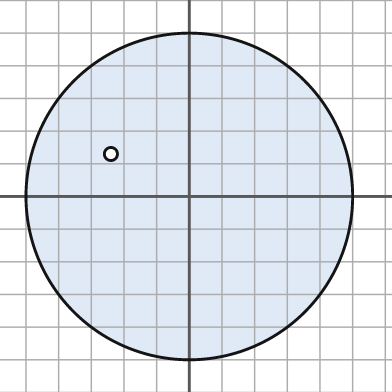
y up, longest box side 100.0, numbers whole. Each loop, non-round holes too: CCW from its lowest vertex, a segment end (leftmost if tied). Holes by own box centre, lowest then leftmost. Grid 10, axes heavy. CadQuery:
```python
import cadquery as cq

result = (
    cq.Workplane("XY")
    .moveTo(0.0, 0.0)
    .circle(50.0)
    .moveTo(-24.0, 13.0)
    .circle(2.0)
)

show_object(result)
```